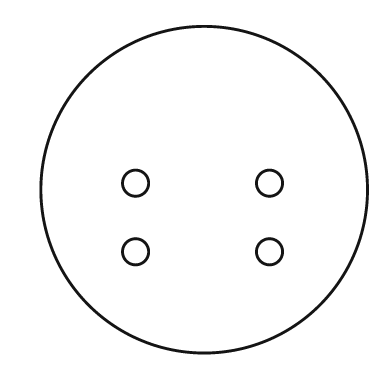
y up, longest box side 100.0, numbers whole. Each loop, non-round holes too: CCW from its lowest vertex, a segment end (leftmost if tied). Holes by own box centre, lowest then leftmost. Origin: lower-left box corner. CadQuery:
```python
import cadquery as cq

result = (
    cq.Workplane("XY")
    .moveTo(50.0, 50.0)
    .circle(50.0)
    .moveTo(29.0, 31.0)
    .circle(4.0)
    .moveTo(70.0, 31.0)
    .circle(4.0)
    .moveTo(29.0, 52.0)
    .circle(4.0)
    .moveTo(70.0, 52.0)
    .circle(4.0)
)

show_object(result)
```